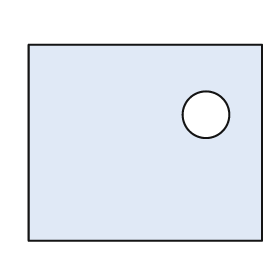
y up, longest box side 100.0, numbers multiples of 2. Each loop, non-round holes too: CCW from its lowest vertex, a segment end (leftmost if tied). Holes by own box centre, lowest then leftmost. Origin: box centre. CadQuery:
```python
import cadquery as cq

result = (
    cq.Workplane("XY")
    .moveTo(-50.0, -42.0)
    .lineTo(50.0, -42.0)
    .lineTo(50.0, 42.0)
    .lineTo(-50.0, 42.0)
    .close()
    .moveTo(26.0, 12.0)
    .circle(10.0)
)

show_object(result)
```